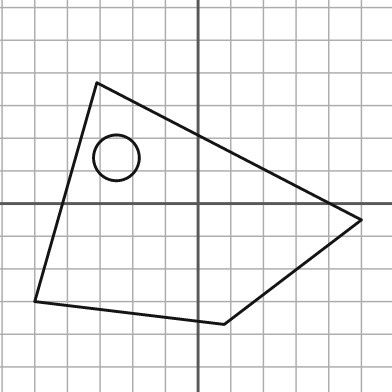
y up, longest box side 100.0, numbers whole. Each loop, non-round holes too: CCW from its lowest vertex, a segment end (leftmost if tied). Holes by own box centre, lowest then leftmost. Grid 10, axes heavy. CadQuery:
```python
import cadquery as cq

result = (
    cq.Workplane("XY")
    .moveTo(8.0, -37.0)
    .lineTo(50.0, -5.0)
    .lineTo(-31.0, 37.0)
    .lineTo(-50.0, -30.0)
    .close()
    .moveTo(-25.0, 14.0)
    .circle(7.0)
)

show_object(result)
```